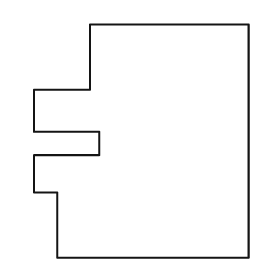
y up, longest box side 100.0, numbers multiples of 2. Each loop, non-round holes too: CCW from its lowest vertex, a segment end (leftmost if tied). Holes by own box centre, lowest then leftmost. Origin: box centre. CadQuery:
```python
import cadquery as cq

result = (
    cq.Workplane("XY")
    .moveTo(-36.0, -50.0)
    .lineTo(46.0, -50.0)
    .lineTo(46.0, 50.0)
    .lineTo(-22.0, 50.0)
    .lineTo(-22.0, 22.0)
    .lineTo(-46.0, 22.0)
    .lineTo(-46.0, 4.0)
    .lineTo(-18.0, 4.0)
    .lineTo(-18.0, -6.0)
    .lineTo(-46.0, -6.0)
    .lineTo(-46.0, -22.0)
    .lineTo(-36.0, -22.0)
    .close()
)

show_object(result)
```